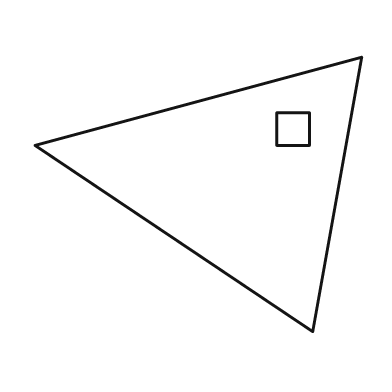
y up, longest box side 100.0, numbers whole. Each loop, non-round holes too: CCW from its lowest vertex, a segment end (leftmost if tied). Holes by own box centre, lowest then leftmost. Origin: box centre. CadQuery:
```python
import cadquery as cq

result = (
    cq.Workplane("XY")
    .moveTo(35.0, -42.0)
    .lineTo(50.0, 42.0)
    .lineTo(-50.0, 15.0)
    .close()
    .moveTo(24.0, 15.0)
    .lineTo(34.0, 15.0)
    .lineTo(34.0, 25.0)
    .lineTo(24.0, 25.0)
    .close()
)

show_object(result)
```